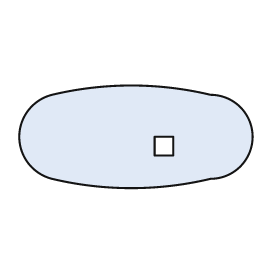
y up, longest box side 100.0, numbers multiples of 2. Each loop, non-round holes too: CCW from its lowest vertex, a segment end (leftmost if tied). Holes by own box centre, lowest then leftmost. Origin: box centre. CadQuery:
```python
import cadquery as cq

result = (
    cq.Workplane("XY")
    .moveTo(-36.0, -18.0)
    .threePointArc((-2.0, -22.0), (32.0, -18.0))
    .threePointArc((50.0, 0.0), (32.0, 18.0))
    .threePointArc((-2.0, 22.0), (-36.0, 18.0))
    .threePointArc((-50.0, 0.0), (-36.0, -18.0))
    .close()
    .moveTo(8.0, -8.0)
    .lineTo(16.0, -8.0)
    .lineTo(16.0, 0.0)
    .lineTo(8.0, 0.0)
    .close()
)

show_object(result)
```